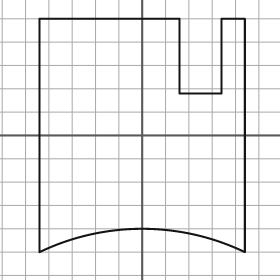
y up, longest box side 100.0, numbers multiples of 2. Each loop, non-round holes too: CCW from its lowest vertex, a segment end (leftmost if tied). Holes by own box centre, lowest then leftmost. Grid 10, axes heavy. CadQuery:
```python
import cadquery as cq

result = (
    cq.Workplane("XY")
    .moveTo(-44.0, -50.0)
    .threePointArc((0.0, -40.0), (44.0, -50.0))
    .lineTo(44.0, 50.0)
    .lineTo(34.0, 50.0)
    .lineTo(34.0, 18.0)
    .lineTo(16.0, 18.0)
    .lineTo(16.0, 50.0)
    .lineTo(-44.0, 50.0)
    .close()
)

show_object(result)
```